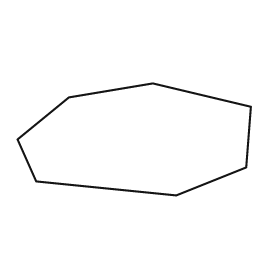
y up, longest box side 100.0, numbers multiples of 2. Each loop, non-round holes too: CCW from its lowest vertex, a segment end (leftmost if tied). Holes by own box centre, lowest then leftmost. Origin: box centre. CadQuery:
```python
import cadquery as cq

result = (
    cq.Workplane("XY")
    .moveTo(18.0, -24.0)
    .lineTo(48.0, -12.0)
    .lineTo(50.0, 14.0)
    .lineTo(8.0, 24.0)
    .lineTo(-28.0, 18.0)
    .lineTo(-50.0, 0.0)
    .lineTo(-42.0, -18.0)
    .close()
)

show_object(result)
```